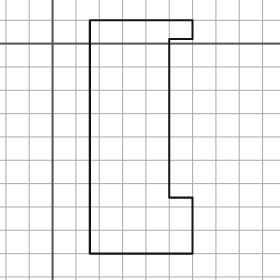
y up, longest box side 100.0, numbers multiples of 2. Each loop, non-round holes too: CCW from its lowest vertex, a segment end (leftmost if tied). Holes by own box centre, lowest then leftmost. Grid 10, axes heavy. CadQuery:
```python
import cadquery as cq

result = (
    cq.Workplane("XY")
    .moveTo(16.0, -90.0)
    .lineTo(60.0, -90.0)
    .lineTo(60.0, -66.0)
    .lineTo(50.0, -66.0)
    .lineTo(50.0, 2.0)
    .lineTo(60.0, 2.0)
    .lineTo(60.0, 10.0)
    .lineTo(16.0, 10.0)
    .close()
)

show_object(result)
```